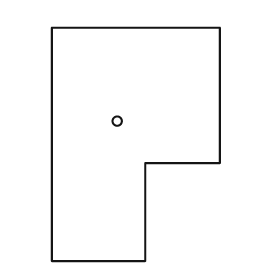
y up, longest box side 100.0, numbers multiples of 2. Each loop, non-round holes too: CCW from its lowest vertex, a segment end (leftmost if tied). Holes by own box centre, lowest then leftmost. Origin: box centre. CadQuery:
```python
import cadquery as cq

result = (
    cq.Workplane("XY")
    .moveTo(-36.0, -50.0)
    .lineTo(4.0, -50.0)
    .lineTo(4.0, -8.0)
    .lineTo(36.0, -8.0)
    .lineTo(36.0, 50.0)
    .lineTo(-36.0, 50.0)
    .close()
    .moveTo(-8.0, 10.0)
    .circle(2.0)
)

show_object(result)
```